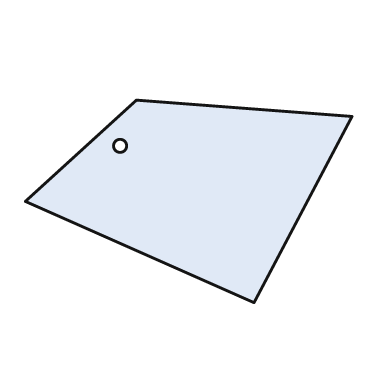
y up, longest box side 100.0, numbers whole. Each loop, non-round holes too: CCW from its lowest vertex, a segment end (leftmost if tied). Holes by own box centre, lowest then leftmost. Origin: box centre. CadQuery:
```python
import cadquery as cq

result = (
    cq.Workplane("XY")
    .moveTo(20.0, -31.0)
    .lineTo(50.0, 26.0)
    .lineTo(-16.0, 31.0)
    .lineTo(-50.0, 0.0)
    .close()
    .moveTo(-21.0, 17.0)
    .circle(2.0)
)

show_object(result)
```